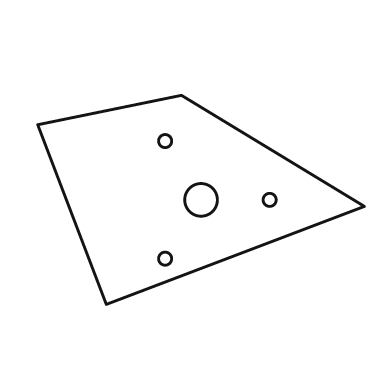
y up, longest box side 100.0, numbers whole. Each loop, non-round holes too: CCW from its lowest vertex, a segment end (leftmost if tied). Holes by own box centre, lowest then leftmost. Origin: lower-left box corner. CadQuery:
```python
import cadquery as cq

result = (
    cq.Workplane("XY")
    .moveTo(21.0, 0.0)
    .lineTo(100.0, 30.0)
    .lineTo(44.0, 64.0)
    .lineTo(0.0, 55.0)
    .close()
    .moveTo(39.0, 14.0)
    .circle(2.0)
    .moveTo(50.0, 32.0)
    .circle(5.0)
    .moveTo(71.0, 32.0)
    .circle(2.0)
    .moveTo(39.0, 50.0)
    .circle(2.0)
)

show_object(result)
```